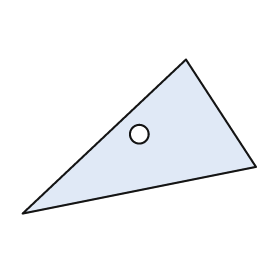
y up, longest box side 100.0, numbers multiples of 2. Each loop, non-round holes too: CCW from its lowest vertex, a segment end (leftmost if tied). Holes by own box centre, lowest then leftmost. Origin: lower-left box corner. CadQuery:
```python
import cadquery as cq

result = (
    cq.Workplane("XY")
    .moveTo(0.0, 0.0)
    .lineTo(100.0, 20.0)
    .lineTo(70.0, 66.0)
    .close()
    .moveTo(50.0, 34.0)
    .circle(4.0)
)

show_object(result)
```